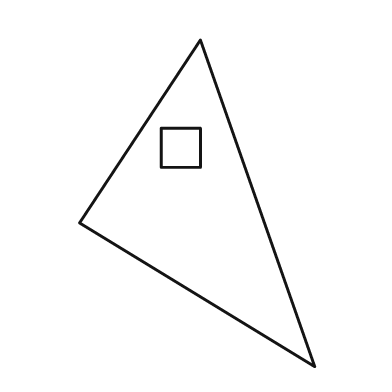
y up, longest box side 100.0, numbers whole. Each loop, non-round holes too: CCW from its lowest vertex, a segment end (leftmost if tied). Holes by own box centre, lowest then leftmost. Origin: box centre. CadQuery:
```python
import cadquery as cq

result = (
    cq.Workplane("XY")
    .moveTo(36.0, -50.0)
    .lineTo(1.0, 50.0)
    .lineTo(-36.0, -6.0)
    .close()
    .moveTo(-11.0, 11.0)
    .lineTo(1.0, 11.0)
    .lineTo(1.0, 23.0)
    .lineTo(-11.0, 23.0)
    .close()
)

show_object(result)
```